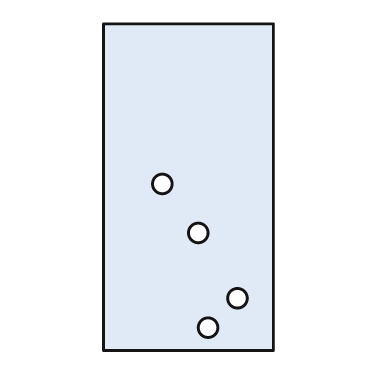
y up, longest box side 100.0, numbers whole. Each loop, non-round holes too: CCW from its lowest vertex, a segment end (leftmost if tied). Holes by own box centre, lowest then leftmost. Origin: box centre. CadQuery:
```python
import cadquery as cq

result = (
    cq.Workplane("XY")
    .moveTo(-26.0, -50.0)
    .lineTo(26.0, -50.0)
    .lineTo(26.0, 50.0)
    .lineTo(-26.0, 50.0)
    .close()
    .moveTo(6.0, -43.0)
    .circle(3.0)
    .moveTo(15.0, -34.0)
    .circle(3.0)
    .moveTo(3.0, -14.0)
    .circle(3.0)
    .moveTo(-8.0, 1.0)
    .circle(3.0)
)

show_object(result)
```